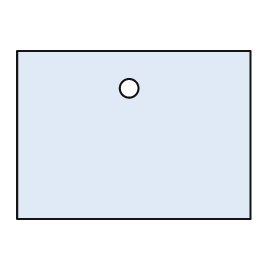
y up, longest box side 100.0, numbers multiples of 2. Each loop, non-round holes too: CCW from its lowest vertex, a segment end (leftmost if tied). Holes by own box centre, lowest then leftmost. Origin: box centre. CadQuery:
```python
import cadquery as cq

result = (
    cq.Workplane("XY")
    .moveTo(-50.0, -36.0)
    .lineTo(50.0, -36.0)
    .lineTo(50.0, 36.0)
    .lineTo(-50.0, 36.0)
    .close()
    .moveTo(-2.0, 20.0)
    .circle(4.0)
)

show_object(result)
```